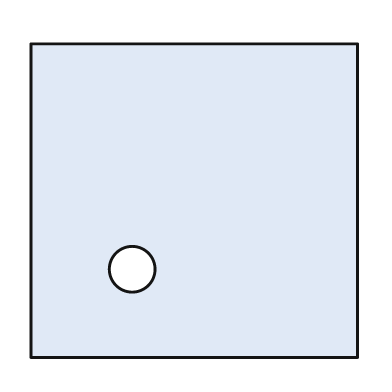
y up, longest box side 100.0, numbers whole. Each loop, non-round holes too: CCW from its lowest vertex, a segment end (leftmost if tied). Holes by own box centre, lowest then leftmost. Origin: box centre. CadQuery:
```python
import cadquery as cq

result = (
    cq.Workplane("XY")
    .moveTo(-50.0, -48.0)
    .lineTo(50.0, -48.0)
    .lineTo(50.0, 48.0)
    .lineTo(-50.0, 48.0)
    .close()
    .moveTo(-19.0, -21.0)
    .circle(7.0)
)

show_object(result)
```